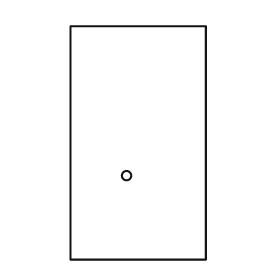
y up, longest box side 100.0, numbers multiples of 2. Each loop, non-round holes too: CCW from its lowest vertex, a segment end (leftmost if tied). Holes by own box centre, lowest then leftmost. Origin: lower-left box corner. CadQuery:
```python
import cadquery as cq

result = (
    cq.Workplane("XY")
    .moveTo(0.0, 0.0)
    .lineTo(58.0, 0.0)
    .lineTo(58.0, 100.0)
    .lineTo(0.0, 100.0)
    .close()
    .moveTo(24.0, 36.0)
    .circle(2.0)
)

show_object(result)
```